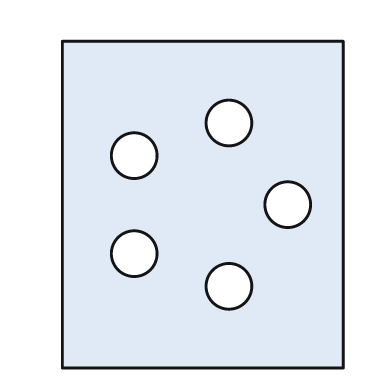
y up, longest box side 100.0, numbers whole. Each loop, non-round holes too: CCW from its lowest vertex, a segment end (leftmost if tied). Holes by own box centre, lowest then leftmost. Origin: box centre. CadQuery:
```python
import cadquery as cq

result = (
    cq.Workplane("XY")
    .moveTo(-43.0, -50.0)
    .lineTo(43.0, -50.0)
    .lineTo(43.0, 50.0)
    .lineTo(-43.0, 50.0)
    .close()
    .moveTo(8.0, -25.0)
    .circle(7.0)
    .moveTo(-21.0, -15.0)
    .circle(7.0)
    .moveTo(26.0, 0.0)
    .circle(7.0)
    .moveTo(-21.0, 15.0)
    .circle(7.0)
    .moveTo(8.0, 25.0)
    .circle(7.0)
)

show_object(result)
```